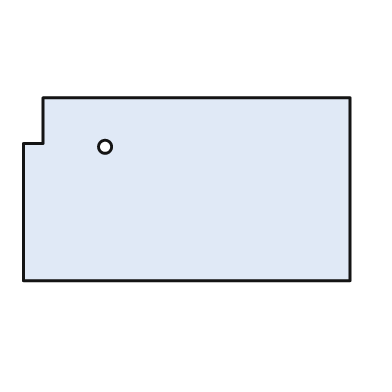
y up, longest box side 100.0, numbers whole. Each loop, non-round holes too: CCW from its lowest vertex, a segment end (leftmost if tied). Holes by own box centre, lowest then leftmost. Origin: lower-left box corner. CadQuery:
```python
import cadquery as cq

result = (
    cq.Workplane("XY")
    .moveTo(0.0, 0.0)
    .lineTo(100.0, 0.0)
    .lineTo(100.0, 56.0)
    .lineTo(6.0, 56.0)
    .lineTo(6.0, 42.0)
    .lineTo(0.0, 42.0)
    .close()
    .moveTo(25.0, 41.0)
    .circle(2.0)
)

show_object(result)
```